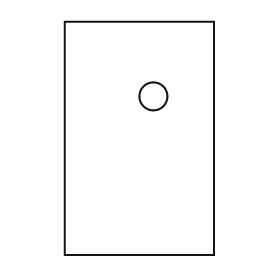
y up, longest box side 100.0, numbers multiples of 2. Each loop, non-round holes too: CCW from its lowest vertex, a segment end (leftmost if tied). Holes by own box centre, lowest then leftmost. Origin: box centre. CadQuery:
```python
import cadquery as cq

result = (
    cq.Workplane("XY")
    .moveTo(-32.0, -50.0)
    .lineTo(32.0, -50.0)
    .lineTo(32.0, 50.0)
    .lineTo(-32.0, 50.0)
    .close()
    .moveTo(6.0, 18.0)
    .circle(6.0)
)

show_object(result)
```